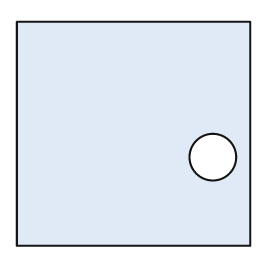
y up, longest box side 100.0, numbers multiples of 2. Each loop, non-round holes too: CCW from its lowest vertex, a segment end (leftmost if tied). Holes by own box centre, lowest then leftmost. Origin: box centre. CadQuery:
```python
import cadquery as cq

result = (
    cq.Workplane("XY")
    .moveTo(-50.0, -48.0)
    .lineTo(50.0, -48.0)
    .lineTo(50.0, 48.0)
    .lineTo(-50.0, 48.0)
    .close()
    .moveTo(34.0, -10.0)
    .circle(10.0)
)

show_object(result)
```